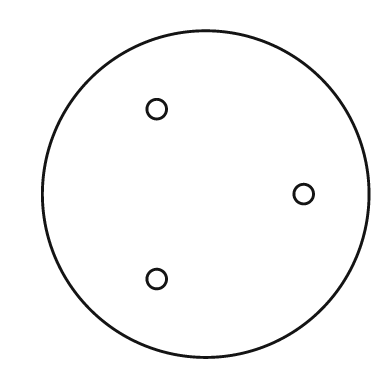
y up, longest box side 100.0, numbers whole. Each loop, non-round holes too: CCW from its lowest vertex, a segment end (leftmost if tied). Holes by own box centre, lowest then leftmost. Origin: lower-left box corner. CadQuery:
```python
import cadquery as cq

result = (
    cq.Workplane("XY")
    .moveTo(50.0, 50.0)
    .circle(50.0)
    .moveTo(35.0, 24.0)
    .circle(3.0)
    .moveTo(80.0, 50.0)
    .circle(3.0)
    .moveTo(35.0, 76.0)
    .circle(3.0)
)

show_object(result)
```